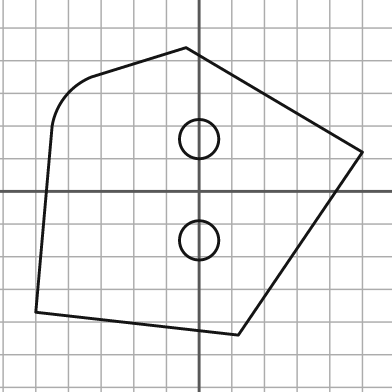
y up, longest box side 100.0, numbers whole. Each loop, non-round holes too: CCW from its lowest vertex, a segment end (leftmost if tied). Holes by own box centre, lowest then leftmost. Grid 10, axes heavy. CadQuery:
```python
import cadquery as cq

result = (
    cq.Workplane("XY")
    .moveTo(12.0, -44.0)
    .lineTo(50.0, 12.0)
    .lineTo(-4.0, 44.0)
    .lineTo(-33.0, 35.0)
    .threePointArc((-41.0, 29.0), (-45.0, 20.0))
    .lineTo(-50.0, -37.0)
    .close()
    .moveTo(0.0, -15.0)
    .circle(6.0)
    .moveTo(0.0, 16.0)
    .circle(6.0)
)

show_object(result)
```